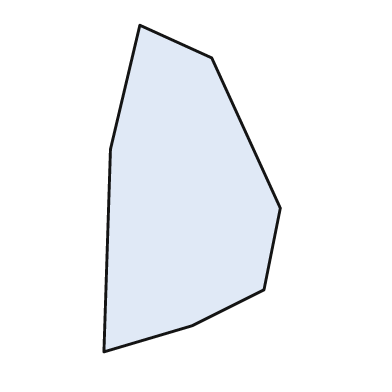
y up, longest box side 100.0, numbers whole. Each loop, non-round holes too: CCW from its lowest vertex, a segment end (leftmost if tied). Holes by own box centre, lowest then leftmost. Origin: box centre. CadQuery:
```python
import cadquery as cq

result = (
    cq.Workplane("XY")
    .moveTo(-27.0, -50.0)
    .lineTo(0.0, -42.0)
    .lineTo(22.0, -31.0)
    .lineTo(27.0, -6.0)
    .lineTo(6.0, 40.0)
    .lineTo(-16.0, 50.0)
    .lineTo(-25.0, 12.0)
    .close()
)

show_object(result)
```